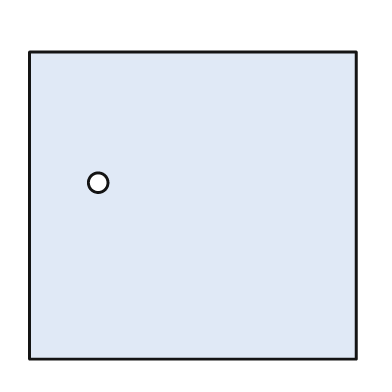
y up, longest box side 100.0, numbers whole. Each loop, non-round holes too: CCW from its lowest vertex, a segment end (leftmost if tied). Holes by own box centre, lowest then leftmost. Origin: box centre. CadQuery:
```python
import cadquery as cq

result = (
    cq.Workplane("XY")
    .moveTo(-50.0, -47.0)
    .lineTo(50.0, -47.0)
    .lineTo(50.0, 47.0)
    .lineTo(-50.0, 47.0)
    .close()
    .moveTo(-29.0, 7.0)
    .circle(3.0)
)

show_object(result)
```